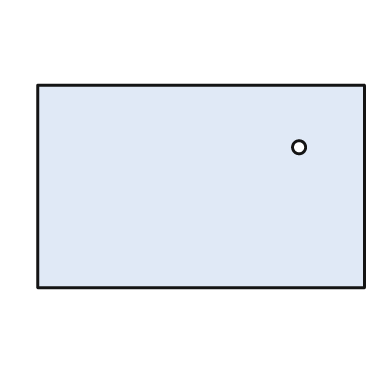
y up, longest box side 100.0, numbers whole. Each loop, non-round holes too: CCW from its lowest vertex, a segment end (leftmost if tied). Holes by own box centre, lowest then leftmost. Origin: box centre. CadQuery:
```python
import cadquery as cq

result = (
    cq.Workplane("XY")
    .moveTo(-50.0, -31.0)
    .lineTo(50.0, -31.0)
    .lineTo(50.0, 31.0)
    .lineTo(-50.0, 31.0)
    .close()
    .moveTo(30.0, 12.0)
    .circle(2.0)
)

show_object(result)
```